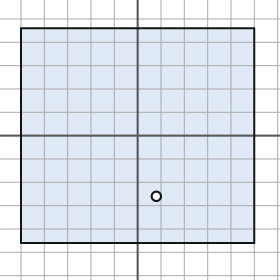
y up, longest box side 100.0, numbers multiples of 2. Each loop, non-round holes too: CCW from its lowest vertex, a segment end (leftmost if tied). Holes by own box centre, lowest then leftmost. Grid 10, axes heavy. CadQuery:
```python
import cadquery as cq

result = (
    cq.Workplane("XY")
    .moveTo(-50.0, -46.0)
    .lineTo(50.0, -46.0)
    .lineTo(50.0, 46.0)
    .lineTo(-50.0, 46.0)
    .close()
    .moveTo(8.0, -26.0)
    .circle(2.0)
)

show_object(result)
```